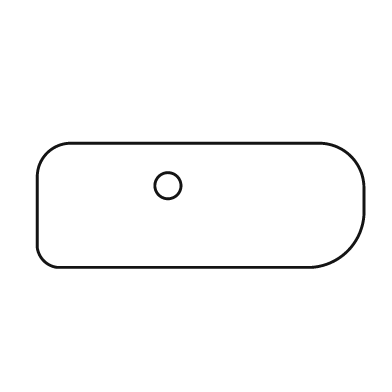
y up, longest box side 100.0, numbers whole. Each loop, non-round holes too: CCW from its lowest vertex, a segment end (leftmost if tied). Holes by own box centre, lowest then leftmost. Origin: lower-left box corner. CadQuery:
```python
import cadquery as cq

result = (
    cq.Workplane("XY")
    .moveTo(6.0, 0.0)
    .lineTo(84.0, 0.0)
    .threePointArc((95.0, 5.0), (100.0, 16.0))
    .lineTo(100.0, 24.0)
    .threePointArc((96.0, 34.0), (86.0, 38.0))
    .lineTo(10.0, 38.0)
    .threePointArc((3.0, 35.0), (0.0, 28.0))
    .lineTo(0.0, 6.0)
    .threePointArc((2.0, 2.0), (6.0, 0.0))
    .close()
    .moveTo(40.0, 25.0)
    .circle(4.0)
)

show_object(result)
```